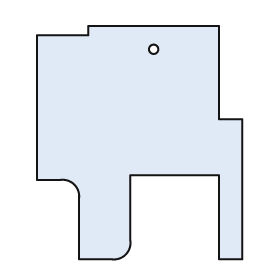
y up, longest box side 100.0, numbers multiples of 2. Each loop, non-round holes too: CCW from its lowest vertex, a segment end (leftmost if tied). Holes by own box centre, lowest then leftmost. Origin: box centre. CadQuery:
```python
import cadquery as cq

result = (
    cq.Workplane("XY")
    .moveTo(-26.0, -50.0)
    .lineTo(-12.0, -50.0)
    .threePointArc((-6.0, -48.0), (-4.0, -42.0))
    .lineTo(-4.0, -14.0)
    .lineTo(34.0, -14.0)
    .lineTo(34.0, -50.0)
    .lineTo(44.0, -50.0)
    .lineTo(44.0, 10.0)
    .lineTo(34.0, 10.0)
    .lineTo(34.0, 50.0)
    .lineTo(-22.0, 50.0)
    .lineTo(-22.0, 46.0)
    .lineTo(-44.0, 46.0)
    .lineTo(-44.0, -16.0)
    .lineTo(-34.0, -16.0)
    .threePointArc((-28.0, -18.0), (-26.0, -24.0))
    .close()
    .moveTo(6.0, 40.0)
    .circle(2.0)
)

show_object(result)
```